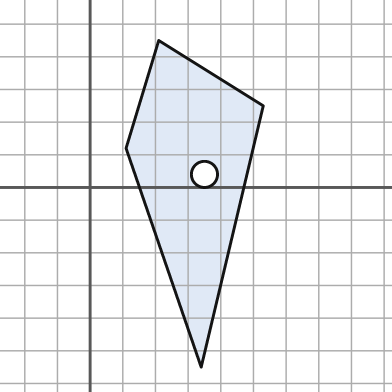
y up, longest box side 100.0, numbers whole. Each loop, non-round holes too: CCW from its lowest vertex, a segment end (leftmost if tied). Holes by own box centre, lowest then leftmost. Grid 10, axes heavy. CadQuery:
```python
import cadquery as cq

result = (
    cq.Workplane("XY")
    .moveTo(34.0, -55.0)
    .lineTo(53.0, 25.0)
    .lineTo(21.0, 45.0)
    .lineTo(11.0, 12.0)
    .close()
    .moveTo(35.0, 4.0)
    .circle(4.0)
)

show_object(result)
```